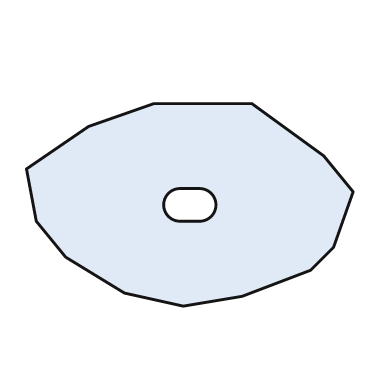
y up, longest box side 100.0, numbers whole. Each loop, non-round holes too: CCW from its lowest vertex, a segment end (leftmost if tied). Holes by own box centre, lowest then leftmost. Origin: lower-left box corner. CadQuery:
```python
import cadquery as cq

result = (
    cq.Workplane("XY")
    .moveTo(48.0, 0.0)
    .lineTo(66.0, 3.0)
    .lineTo(87.0, 11.0)
    .lineTo(94.0, 18.0)
    .lineTo(100.0, 35.0)
    .lineTo(91.0, 46.0)
    .lineTo(69.0, 62.0)
    .lineTo(39.0, 62.0)
    .lineTo(19.0, 55.0)
    .lineTo(0.0, 42.0)
    .lineTo(3.0, 26.0)
    .lineTo(12.0, 15.0)
    .lineTo(30.0, 4.0)
    .close()
    .moveTo(47.0, 26.0)
    .lineTo(53.0, 26.0)
    .threePointArc((58.0, 31.0), (53.0, 36.0))
    .lineTo(47.0, 36.0)
    .threePointArc((42.0, 31.0), (47.0, 26.0))
    .close()
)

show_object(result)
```